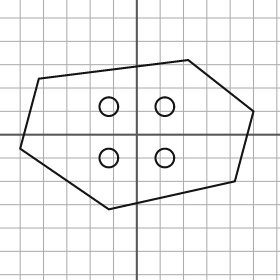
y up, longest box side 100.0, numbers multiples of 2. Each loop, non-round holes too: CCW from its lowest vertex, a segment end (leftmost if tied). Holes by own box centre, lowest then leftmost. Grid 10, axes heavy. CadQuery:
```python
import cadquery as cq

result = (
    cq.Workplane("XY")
    .moveTo(-12.0, -32.0)
    .lineTo(42.0, -20.0)
    .lineTo(50.0, 10.0)
    .lineTo(22.0, 32.0)
    .lineTo(-42.0, 24.0)
    .lineTo(-50.0, -6.0)
    .close()
    .moveTo(-12.0, -10.0)
    .circle(4.0)
    .moveTo(12.0, -10.0)
    .circle(4.0)
    .moveTo(-12.0, 12.0)
    .circle(4.0)
    .moveTo(12.0, 12.0)
    .circle(4.0)
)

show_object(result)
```